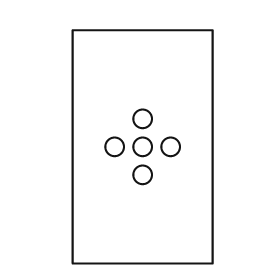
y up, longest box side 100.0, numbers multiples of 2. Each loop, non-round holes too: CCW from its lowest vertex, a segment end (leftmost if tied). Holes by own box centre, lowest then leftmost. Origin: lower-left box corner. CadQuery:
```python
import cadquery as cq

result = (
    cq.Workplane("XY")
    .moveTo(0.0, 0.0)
    .lineTo(60.0, 0.0)
    .lineTo(60.0, 100.0)
    .lineTo(0.0, 100.0)
    .close()
    .moveTo(30.0, 38.0)
    .circle(4.0)
    .moveTo(18.0, 50.0)
    .circle(4.0)
    .moveTo(30.0, 50.0)
    .circle(4.0)
    .moveTo(42.0, 50.0)
    .circle(4.0)
    .moveTo(30.0, 62.0)
    .circle(4.0)
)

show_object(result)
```